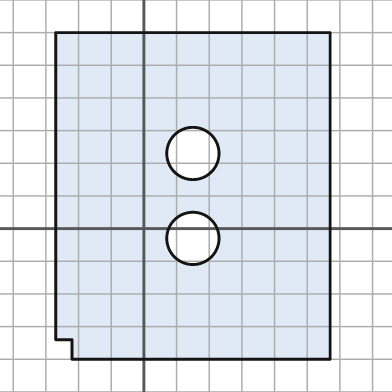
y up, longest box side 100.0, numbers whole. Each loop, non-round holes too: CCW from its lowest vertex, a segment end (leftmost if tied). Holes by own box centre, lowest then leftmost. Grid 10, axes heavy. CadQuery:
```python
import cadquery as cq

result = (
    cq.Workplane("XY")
    .moveTo(-22.0, -40.0)
    .lineTo(57.0, -40.0)
    .lineTo(57.0, 60.0)
    .lineTo(-27.0, 60.0)
    .lineTo(-27.0, -34.0)
    .lineTo(-22.0, -34.0)
    .close()
    .moveTo(15.0, -3.0)
    .circle(8.0)
    .moveTo(15.0, 23.0)
    .circle(8.0)
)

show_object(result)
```